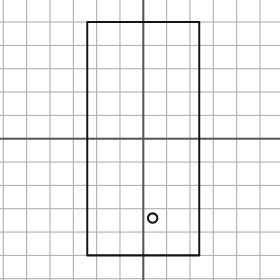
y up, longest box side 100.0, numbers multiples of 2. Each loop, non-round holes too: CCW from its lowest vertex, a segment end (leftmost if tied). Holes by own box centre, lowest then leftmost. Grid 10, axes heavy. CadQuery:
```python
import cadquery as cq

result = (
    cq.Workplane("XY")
    .moveTo(-24.0, -50.0)
    .lineTo(24.0, -50.0)
    .lineTo(24.0, 50.0)
    .lineTo(-24.0, 50.0)
    .close()
    .moveTo(4.0, -34.0)
    .circle(2.0)
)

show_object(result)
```